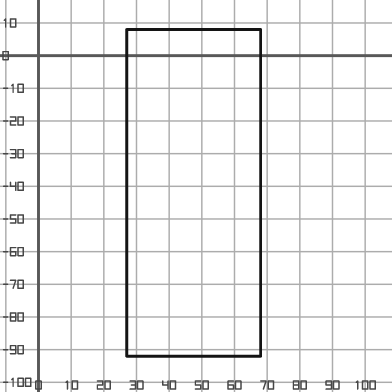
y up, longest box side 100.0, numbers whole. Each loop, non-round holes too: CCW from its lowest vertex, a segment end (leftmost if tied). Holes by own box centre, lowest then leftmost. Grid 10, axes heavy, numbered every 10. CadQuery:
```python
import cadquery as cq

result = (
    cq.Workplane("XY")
    .moveTo(27.0, -92.0)
    .lineTo(68.0, -92.0)
    .lineTo(68.0, 8.0)
    .lineTo(27.0, 8.0)
    .close()
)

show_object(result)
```